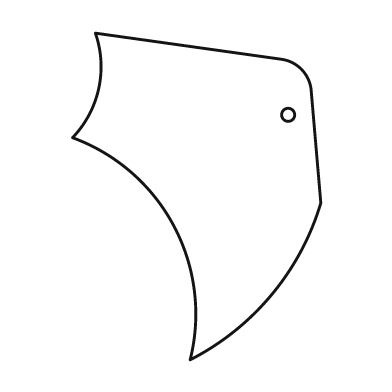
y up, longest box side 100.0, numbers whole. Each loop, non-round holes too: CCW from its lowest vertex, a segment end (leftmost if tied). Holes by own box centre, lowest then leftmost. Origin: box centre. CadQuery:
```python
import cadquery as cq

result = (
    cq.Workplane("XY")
    .moveTo(-2.0, -50.0)
    .threePointArc((23.0, -30.0), (38.0, -2.0))
    .lineTo(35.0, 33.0)
    .threePointArc((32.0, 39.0), (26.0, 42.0))
    .lineTo(-31.0, 50.0)
    .threePointArc((-30.0, 33.0), (-38.0, 18.0))
    .threePointArc((-7.0, -9.0), (-2.0, -50.0))
    .close()
    .moveTo(28.0, 25.0)
    .circle(2.0)
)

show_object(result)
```